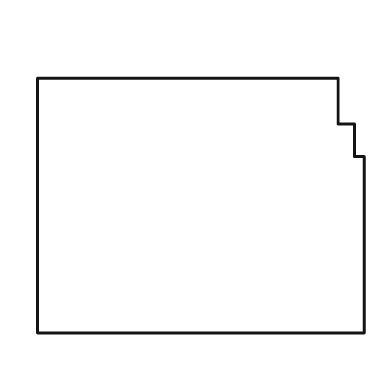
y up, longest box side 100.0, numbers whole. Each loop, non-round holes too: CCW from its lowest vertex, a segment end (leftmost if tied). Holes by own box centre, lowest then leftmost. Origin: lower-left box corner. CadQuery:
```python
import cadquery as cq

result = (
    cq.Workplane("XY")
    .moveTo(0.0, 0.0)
    .lineTo(100.0, 0.0)
    .lineTo(100.0, 54.0)
    .lineTo(97.0, 54.0)
    .lineTo(97.0, 64.0)
    .lineTo(92.0, 64.0)
    .lineTo(92.0, 78.0)
    .lineTo(0.0, 78.0)
    .close()
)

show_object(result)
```